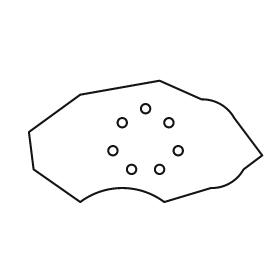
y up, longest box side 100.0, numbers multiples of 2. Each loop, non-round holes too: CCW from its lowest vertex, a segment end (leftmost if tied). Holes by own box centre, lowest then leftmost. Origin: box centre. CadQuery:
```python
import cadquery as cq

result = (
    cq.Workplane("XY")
    .moveTo(-28.0, -26.0)
    .threePointArc((-10.0, -20.0), (8.0, -26.0))
    .lineTo(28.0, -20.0)
    .threePointArc((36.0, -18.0), (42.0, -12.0))
    .lineTo(50.0, -6.0)
    .lineTo(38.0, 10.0)
    .threePointArc((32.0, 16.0), (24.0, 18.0))
    .lineTo(6.0, 26.0)
    .lineTo(-28.0, 20.0)
    .lineTo(-50.0, 4.0)
    .lineTo(-48.0, -12.0)
    .close()
    .moveTo(-6.0, -12.0)
    .circle(2.0)
    .moveTo(6.0, -12.0)
    .circle(2.0)
    .moveTo(-14.0, -4.0)
    .circle(2.0)
    .moveTo(14.0, -4.0)
    .circle(2.0)
    .moveTo(-10.0, 8.0)
    .circle(2.0)
    .moveTo(10.0, 8.0)
    .circle(2.0)
    .moveTo(0.0, 14.0)
    .circle(2.0)
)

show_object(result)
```